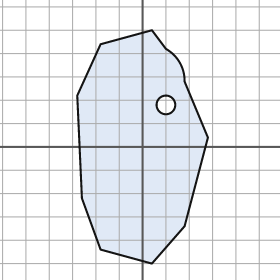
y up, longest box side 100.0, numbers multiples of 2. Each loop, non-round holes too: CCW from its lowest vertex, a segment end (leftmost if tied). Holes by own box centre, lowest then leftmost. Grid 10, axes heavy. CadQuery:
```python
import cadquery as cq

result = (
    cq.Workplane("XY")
    .moveTo(4.0, -50.0)
    .lineTo(18.0, -34.0)
    .lineTo(28.0, 4.0)
    .lineTo(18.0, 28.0)
    .threePointArc((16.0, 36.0), (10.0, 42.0))
    .lineTo(4.0, 50.0)
    .lineTo(-18.0, 44.0)
    .lineTo(-28.0, 22.0)
    .lineTo(-26.0, -22.0)
    .lineTo(-18.0, -44.0)
    .close()
    .moveTo(10.0, 18.0)
    .circle(4.0)
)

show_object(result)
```